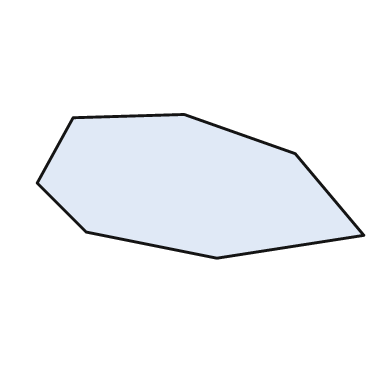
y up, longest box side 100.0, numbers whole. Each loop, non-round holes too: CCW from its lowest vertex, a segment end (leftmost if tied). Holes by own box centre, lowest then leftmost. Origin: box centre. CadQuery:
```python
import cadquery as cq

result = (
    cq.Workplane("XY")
    .moveTo(5.0, -22.0)
    .lineTo(50.0, -15.0)
    .lineTo(29.0, 10.0)
    .lineTo(-5.0, 22.0)
    .lineTo(-39.0, 21.0)
    .lineTo(-50.0, 1.0)
    .lineTo(-35.0, -14.0)
    .close()
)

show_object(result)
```